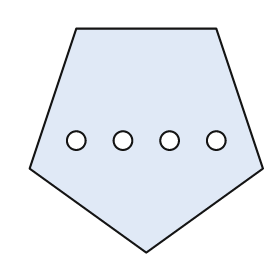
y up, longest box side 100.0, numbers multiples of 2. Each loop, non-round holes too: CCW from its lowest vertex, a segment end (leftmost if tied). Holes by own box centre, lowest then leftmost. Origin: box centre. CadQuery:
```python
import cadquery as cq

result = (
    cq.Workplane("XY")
    .moveTo(0.0, -48.0)
    .lineTo(50.0, -12.0)
    .lineTo(30.0, 48.0)
    .lineTo(-30.0, 48.0)
    .lineTo(-50.0, -12.0)
    .close()
    .moveTo(-30.0, 0.0)
    .circle(4.0)
    .moveTo(-10.0, 0.0)
    .circle(4.0)
    .moveTo(10.0, 0.0)
    .circle(4.0)
    .moveTo(30.0, 0.0)
    .circle(4.0)
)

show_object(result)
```